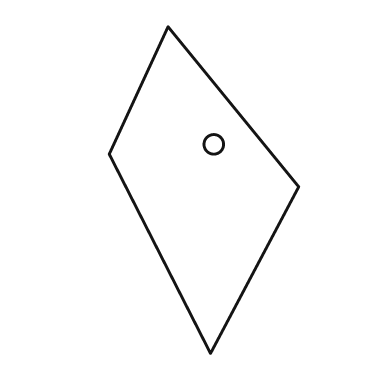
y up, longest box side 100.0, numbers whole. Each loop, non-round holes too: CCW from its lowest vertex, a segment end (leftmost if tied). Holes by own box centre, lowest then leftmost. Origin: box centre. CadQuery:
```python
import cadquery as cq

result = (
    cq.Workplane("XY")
    .moveTo(2.0, -50.0)
    .lineTo(29.0, 1.0)
    .lineTo(-11.0, 50.0)
    .lineTo(-29.0, 11.0)
    .close()
    .moveTo(3.0, 14.0)
    .circle(3.0)
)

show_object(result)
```